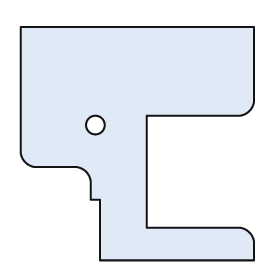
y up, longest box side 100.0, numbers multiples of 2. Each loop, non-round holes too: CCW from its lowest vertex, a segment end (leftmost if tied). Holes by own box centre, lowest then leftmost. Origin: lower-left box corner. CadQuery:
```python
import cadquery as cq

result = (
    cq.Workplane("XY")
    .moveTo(34.0, 0.0)
    .lineTo(100.0, 0.0)
    .lineTo(100.0, 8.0)
    .threePointArc((98.0, 12.0), (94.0, 14.0))
    .lineTo(54.0, 14.0)
    .lineTo(54.0, 62.0)
    .lineTo(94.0, 62.0)
    .threePointArc((98.0, 64.0), (100.0, 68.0))
    .lineTo(100.0, 100.0)
    .lineTo(0.0, 100.0)
    .lineTo(0.0, 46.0)
    .threePointArc((2.0, 42.0), (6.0, 40.0))
    .lineTo(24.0, 40.0)
    .threePointArc((28.0, 38.0), (30.0, 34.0))
    .lineTo(30.0, 26.0)
    .lineTo(34.0, 26.0)
    .close()
    .moveTo(32.0, 58.0)
    .circle(4.0)
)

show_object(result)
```